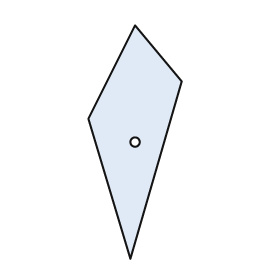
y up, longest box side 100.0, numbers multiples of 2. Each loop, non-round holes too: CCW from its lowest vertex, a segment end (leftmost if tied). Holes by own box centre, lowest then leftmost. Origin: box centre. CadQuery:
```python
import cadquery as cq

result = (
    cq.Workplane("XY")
    .moveTo(-2.0, -50.0)
    .lineTo(20.0, 26.0)
    .lineTo(0.0, 50.0)
    .lineTo(-20.0, 10.0)
    .close()
    .moveTo(0.0, 0.0)
    .circle(2.0)
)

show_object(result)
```